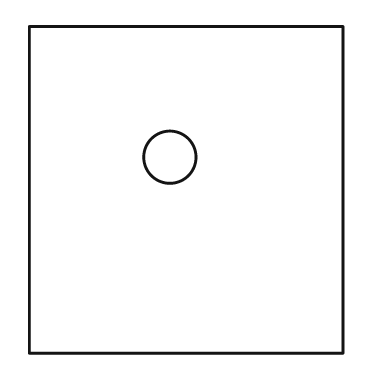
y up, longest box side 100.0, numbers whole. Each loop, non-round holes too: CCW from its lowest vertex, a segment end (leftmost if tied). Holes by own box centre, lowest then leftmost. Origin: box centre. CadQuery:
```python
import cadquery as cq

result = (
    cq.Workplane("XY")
    .moveTo(-48.0, -50.0)
    .lineTo(48.0, -50.0)
    .lineTo(48.0, 50.0)
    .lineTo(-48.0, 50.0)
    .close()
    .moveTo(-5.0, 10.0)
    .circle(8.0)
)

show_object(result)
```